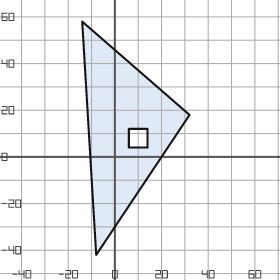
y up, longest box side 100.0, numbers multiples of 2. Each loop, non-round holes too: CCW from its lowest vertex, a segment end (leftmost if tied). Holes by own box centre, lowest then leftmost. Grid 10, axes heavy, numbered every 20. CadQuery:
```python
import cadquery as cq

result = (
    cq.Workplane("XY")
    .moveTo(-8.0, -42.0)
    .lineTo(32.0, 18.0)
    .lineTo(-14.0, 58.0)
    .close()
    .moveTo(6.0, 4.0)
    .lineTo(14.0, 4.0)
    .lineTo(14.0, 12.0)
    .lineTo(6.0, 12.0)
    .close()
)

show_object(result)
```